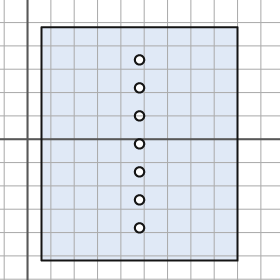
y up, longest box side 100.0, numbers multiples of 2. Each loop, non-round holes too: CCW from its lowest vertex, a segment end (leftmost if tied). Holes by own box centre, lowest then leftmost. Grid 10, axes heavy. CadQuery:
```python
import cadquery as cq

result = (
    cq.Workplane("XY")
    .moveTo(6.0, -52.0)
    .lineTo(90.0, -52.0)
    .lineTo(90.0, 48.0)
    .lineTo(6.0, 48.0)
    .close()
    .moveTo(48.0, -38.0)
    .circle(2.0)
    .moveTo(48.0, -26.0)
    .circle(2.0)
    .moveTo(48.0, -14.0)
    .circle(2.0)
    .moveTo(48.0, -2.0)
    .circle(2.0)
    .moveTo(48.0, 10.0)
    .circle(2.0)
    .moveTo(48.0, 22.0)
    .circle(2.0)
    .moveTo(48.0, 34.0)
    .circle(2.0)
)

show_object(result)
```